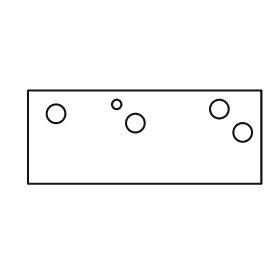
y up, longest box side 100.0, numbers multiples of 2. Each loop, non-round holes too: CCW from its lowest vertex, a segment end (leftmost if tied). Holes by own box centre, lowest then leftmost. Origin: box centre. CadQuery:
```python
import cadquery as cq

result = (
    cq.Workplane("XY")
    .moveTo(-50.0, -20.0)
    .lineTo(50.0, -20.0)
    .lineTo(50.0, 20.0)
    .lineTo(-50.0, 20.0)
    .close()
    .moveTo(42.0, 2.0)
    .circle(4.0)
    .moveTo(-4.0, 6.0)
    .circle(4.0)
    .moveTo(-38.0, 10.0)
    .circle(4.0)
    .moveTo(32.0, 12.0)
    .circle(4.0)
    .moveTo(-12.0, 14.0)
    .circle(2.0)
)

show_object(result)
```